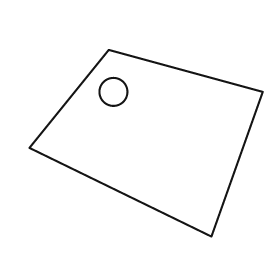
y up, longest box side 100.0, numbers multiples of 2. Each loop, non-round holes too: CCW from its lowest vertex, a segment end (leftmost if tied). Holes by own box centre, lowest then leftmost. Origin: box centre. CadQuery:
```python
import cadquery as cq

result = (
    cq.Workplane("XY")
    .moveTo(28.0, -40.0)
    .lineTo(50.0, 22.0)
    .lineTo(-16.0, 40.0)
    .lineTo(-50.0, -2.0)
    .close()
    .moveTo(-14.0, 22.0)
    .circle(6.0)
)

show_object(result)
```